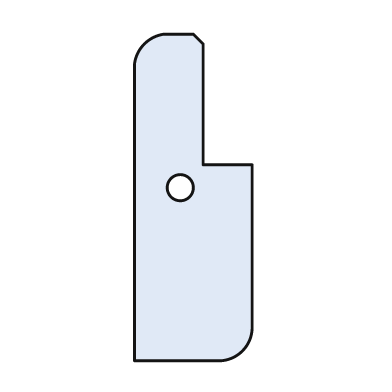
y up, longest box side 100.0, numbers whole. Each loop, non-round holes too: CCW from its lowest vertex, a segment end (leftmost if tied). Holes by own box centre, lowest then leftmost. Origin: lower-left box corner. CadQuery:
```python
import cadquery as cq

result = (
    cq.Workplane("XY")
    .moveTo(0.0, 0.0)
    .lineTo(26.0, 0.0)
    .threePointArc((33.0, 3.0), (36.0, 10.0))
    .lineTo(36.0, 60.0)
    .lineTo(21.0, 60.0)
    .lineTo(21.0, 97.0)
    .lineTo(18.0, 100.0)
    .lineTo(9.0, 100.0)
    .threePointArc((3.0, 97.0), (0.0, 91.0))
    .close()
    .moveTo(14.0, 53.0)
    .circle(4.0)
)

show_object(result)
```